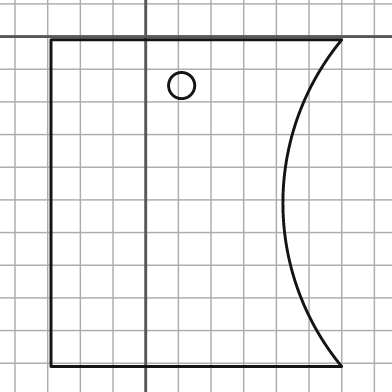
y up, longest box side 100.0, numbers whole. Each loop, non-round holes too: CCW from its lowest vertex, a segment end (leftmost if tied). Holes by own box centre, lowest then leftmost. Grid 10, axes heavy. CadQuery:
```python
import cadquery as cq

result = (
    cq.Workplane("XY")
    .moveTo(-29.0, -101.0)
    .lineTo(60.0, -101.0)
    .threePointArc((42.0, -51.0), (60.0, -1.0))
    .lineTo(-29.0, -1.0)
    .close()
    .moveTo(11.0, -15.0)
    .circle(4.0)
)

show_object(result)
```